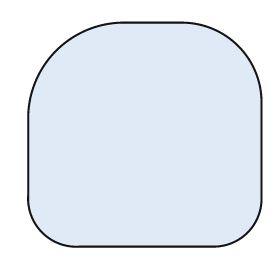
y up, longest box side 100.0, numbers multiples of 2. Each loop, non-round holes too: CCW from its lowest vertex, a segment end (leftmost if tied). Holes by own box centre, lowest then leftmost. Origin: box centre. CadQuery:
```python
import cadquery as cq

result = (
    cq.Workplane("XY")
    .moveTo(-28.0, -48.0)
    .lineTo(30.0, -48.0)
    .threePointArc((44.0, -42.0), (50.0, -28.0))
    .lineTo(50.0, 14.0)
    .threePointArc((40.0, 38.0), (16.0, 48.0))
    .lineTo(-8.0, 48.0)
    .threePointArc((-38.0, 36.0), (-50.0, 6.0))
    .lineTo(-50.0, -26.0)
    .threePointArc((-44.0, -42.0), (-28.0, -48.0))
    .close()
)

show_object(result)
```